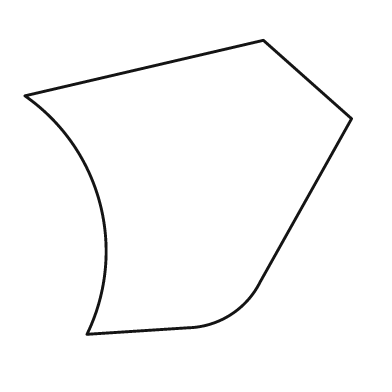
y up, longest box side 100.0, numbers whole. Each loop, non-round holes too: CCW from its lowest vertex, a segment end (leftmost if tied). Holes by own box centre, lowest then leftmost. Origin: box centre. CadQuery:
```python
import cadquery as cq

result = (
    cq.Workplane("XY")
    .moveTo(-31.0, -45.0)
    .lineTo(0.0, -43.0)
    .threePointArc((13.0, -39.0), (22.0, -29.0))
    .lineTo(50.0, 21.0)
    .lineTo(23.0, 45.0)
    .lineTo(-50.0, 28.0)
    .threePointArc((-27.0, -5.0), (-31.0, -45.0))
    .close()
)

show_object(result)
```